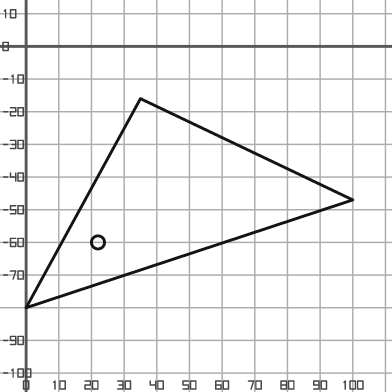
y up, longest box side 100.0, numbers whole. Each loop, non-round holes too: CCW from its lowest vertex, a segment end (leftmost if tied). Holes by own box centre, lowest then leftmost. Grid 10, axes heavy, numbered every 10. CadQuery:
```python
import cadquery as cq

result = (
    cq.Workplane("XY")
    .moveTo(0.0, -80.0)
    .lineTo(100.0, -47.0)
    .lineTo(35.0, -16.0)
    .close()
    .moveTo(22.0, -60.0)
    .circle(2.0)
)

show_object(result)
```